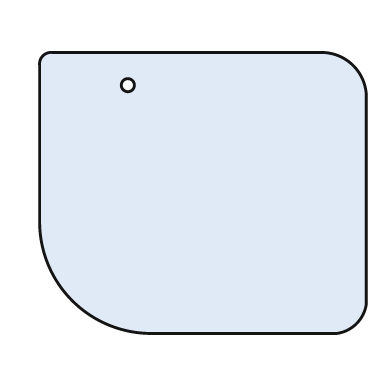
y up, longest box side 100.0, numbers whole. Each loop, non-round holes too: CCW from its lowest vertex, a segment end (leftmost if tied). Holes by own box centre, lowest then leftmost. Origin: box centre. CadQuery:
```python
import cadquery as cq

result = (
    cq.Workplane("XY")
    .moveTo(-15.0, -43.0)
    .lineTo(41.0, -43.0)
    .threePointArc((47.0, -40.0), (50.0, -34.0))
    .lineTo(50.0, 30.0)
    .threePointArc((46.0, 39.0), (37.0, 43.0))
    .lineTo(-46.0, 43.0)
    .threePointArc((-49.0, 42.0), (-50.0, 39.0))
    .lineTo(-50.0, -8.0)
    .threePointArc((-40.0, -33.0), (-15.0, -43.0))
    .close()
    .moveTo(-23.0, 33.0)
    .circle(2.0)
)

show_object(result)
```